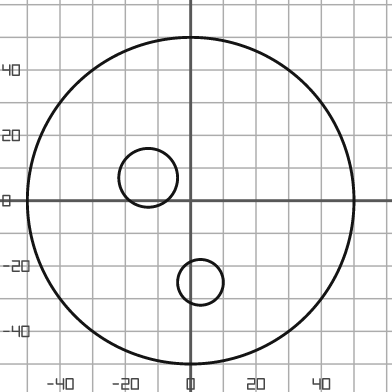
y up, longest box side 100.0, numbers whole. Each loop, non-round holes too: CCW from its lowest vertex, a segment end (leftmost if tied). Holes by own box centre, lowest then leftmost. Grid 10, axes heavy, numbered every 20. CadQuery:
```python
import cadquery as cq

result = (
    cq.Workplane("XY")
    .moveTo(0.0, 0.0)
    .circle(50.0)
    .moveTo(3.0, -25.0)
    .circle(7.0)
    .moveTo(-13.0, 7.0)
    .circle(9.0)
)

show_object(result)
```